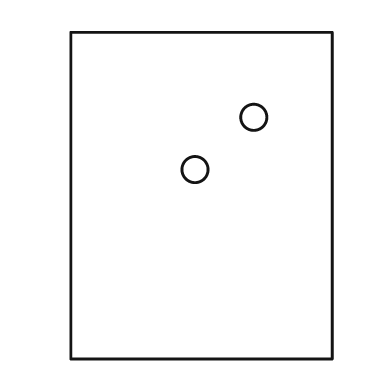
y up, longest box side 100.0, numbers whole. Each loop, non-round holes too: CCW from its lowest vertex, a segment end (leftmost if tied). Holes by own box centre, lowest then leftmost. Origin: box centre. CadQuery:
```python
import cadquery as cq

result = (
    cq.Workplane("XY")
    .moveTo(-40.0, -50.0)
    .lineTo(40.0, -50.0)
    .lineTo(40.0, 50.0)
    .lineTo(-40.0, 50.0)
    .close()
    .moveTo(-2.0, 8.0)
    .circle(4.0)
    .moveTo(16.0, 24.0)
    .circle(4.0)
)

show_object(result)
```